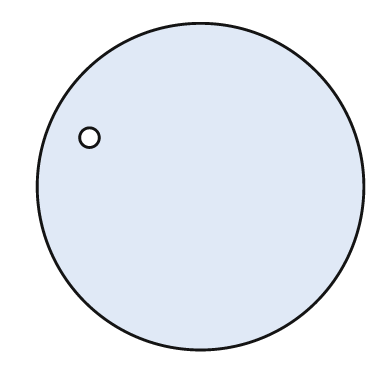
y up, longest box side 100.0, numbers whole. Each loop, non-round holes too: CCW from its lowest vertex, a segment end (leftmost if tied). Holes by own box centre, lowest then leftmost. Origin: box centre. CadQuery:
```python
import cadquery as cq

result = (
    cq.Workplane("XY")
    .moveTo(0.0, 0.0)
    .circle(50.0)
    .moveTo(-34.0, 15.0)
    .circle(3.0)
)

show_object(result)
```